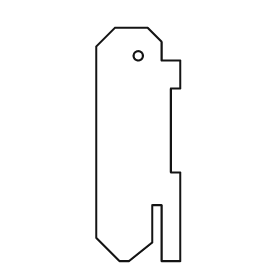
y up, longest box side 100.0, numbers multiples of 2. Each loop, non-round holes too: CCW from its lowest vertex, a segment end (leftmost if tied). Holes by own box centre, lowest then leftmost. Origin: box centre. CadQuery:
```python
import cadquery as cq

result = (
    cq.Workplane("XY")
    .moveTo(-8.0, -50.0)
    .lineTo(-4.0, -50.0)
    .lineTo(6.0, -42.0)
    .lineTo(6.0, -26.0)
    .lineTo(10.0, -26.0)
    .lineTo(10.0, -50.0)
    .lineTo(18.0, -50.0)
    .lineTo(18.0, -12.0)
    .lineTo(14.0, -12.0)
    .lineTo(14.0, 24.0)
    .lineTo(18.0, 24.0)
    .lineTo(18.0, 36.0)
    .lineTo(10.0, 36.0)
    .lineTo(10.0, 44.0)
    .lineTo(4.0, 50.0)
    .lineTo(-10.0, 50.0)
    .lineTo(-18.0, 42.0)
    .lineTo(-18.0, -40.0)
    .close()
    .moveTo(0.0, 38.0)
    .circle(2.0)
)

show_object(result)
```